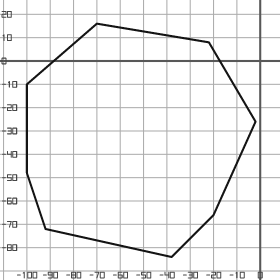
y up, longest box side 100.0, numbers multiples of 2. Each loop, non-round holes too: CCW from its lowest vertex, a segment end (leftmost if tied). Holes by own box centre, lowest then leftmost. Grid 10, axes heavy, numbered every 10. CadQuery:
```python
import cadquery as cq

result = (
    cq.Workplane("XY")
    .moveTo(-38.0, -84.0)
    .lineTo(-20.0, -66.0)
    .lineTo(-2.0, -26.0)
    .lineTo(-22.0, 8.0)
    .lineTo(-70.0, 16.0)
    .lineTo(-100.0, -10.0)
    .lineTo(-100.0, -48.0)
    .lineTo(-92.0, -72.0)
    .close()
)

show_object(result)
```